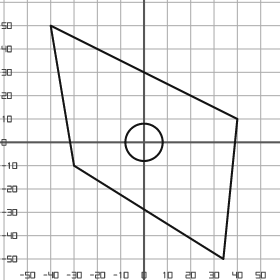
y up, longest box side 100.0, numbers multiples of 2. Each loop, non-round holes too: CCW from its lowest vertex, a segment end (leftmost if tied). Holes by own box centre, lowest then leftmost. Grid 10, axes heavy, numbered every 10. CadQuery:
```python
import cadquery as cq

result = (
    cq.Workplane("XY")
    .moveTo(34.0, -50.0)
    .lineTo(40.0, 10.0)
    .lineTo(-40.0, 50.0)
    .lineTo(-30.0, -10.0)
    .close()
    .moveTo(0.0, 0.0)
    .circle(8.0)
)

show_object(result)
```